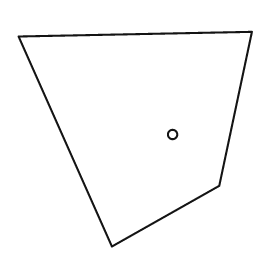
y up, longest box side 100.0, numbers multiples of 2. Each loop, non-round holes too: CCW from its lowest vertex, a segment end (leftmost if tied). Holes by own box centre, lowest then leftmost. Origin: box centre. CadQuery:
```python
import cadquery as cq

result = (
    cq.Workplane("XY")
    .moveTo(-10.0, -46.0)
    .lineTo(36.0, -20.0)
    .lineTo(50.0, 46.0)
    .lineTo(-50.0, 44.0)
    .close()
    .moveTo(16.0, 2.0)
    .circle(2.0)
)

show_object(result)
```